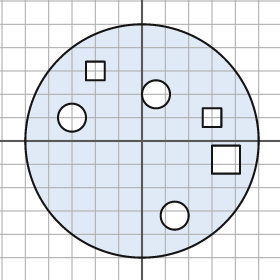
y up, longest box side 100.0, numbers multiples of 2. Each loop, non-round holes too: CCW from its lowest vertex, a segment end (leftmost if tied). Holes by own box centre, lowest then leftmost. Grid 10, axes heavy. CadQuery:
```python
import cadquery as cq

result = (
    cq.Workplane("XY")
    .moveTo(0.0, 0.0)
    .circle(50.0)
    .moveTo(14.0, -32.0)
    .circle(6.0)
    .moveTo(30.0, -14.0)
    .lineTo(42.0, -14.0)
    .lineTo(42.0, -2.0)
    .lineTo(30.0, -2.0)
    .close()
    .moveTo(-30.0, 10.0)
    .circle(6.0)
    .moveTo(26.0, 6.0)
    .lineTo(34.0, 6.0)
    .lineTo(34.0, 14.0)
    .lineTo(26.0, 14.0)
    .close()
    .moveTo(6.0, 20.0)
    .circle(6.0)
    .moveTo(-24.0, 26.0)
    .lineTo(-16.0, 26.0)
    .lineTo(-16.0, 34.0)
    .lineTo(-24.0, 34.0)
    .close()
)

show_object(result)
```